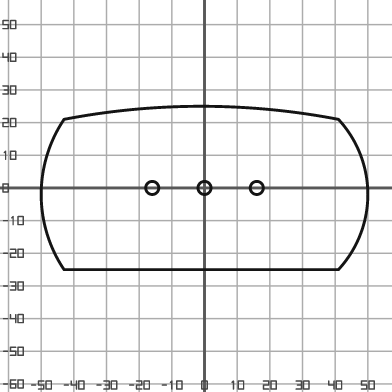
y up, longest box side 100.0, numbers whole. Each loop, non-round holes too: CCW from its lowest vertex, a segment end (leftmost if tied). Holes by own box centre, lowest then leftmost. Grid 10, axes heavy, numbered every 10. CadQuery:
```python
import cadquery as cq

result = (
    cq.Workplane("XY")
    .moveTo(-43.0, -25.0)
    .lineTo(41.0, -25.0)
    .threePointArc((50.0, -2.0), (41.0, 21.0))
    .threePointArc((-1.0, 25.0), (-43.0, 21.0))
    .threePointArc((-50.0, -2.0), (-43.0, -25.0))
    .close()
    .moveTo(-16.0, 0.0)
    .circle(2.0)
    .moveTo(0.0, 0.0)
    .circle(2.0)
    .moveTo(16.0, 0.0)
    .circle(2.0)
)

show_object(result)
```